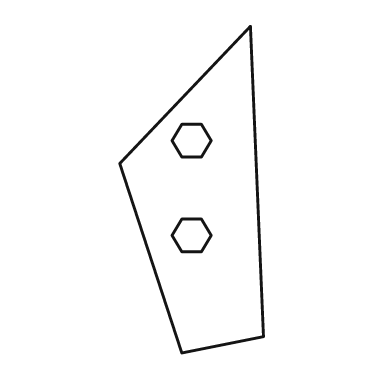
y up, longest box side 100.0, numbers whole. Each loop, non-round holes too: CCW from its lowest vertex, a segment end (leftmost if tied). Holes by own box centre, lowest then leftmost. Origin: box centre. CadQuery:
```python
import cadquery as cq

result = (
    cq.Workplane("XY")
    .moveTo(-3.0, -50.0)
    .lineTo(22.0, -45.0)
    .lineTo(18.0, 50.0)
    .lineTo(-22.0, 8.0)
    .close()
    .moveTo(-3.0, -19.0)
    .lineTo(3.0, -19.0)
    .lineTo(6.0, -14.0)
    .lineTo(3.0, -9.0)
    .lineTo(-3.0, -9.0)
    .lineTo(-6.0, -14.0)
    .close()
    .moveTo(-3.0, 10.0)
    .lineTo(3.0, 10.0)
    .lineTo(6.0, 15.0)
    .lineTo(3.0, 20.0)
    .lineTo(-3.0, 20.0)
    .lineTo(-6.0, 15.0)
    .close()
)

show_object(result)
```